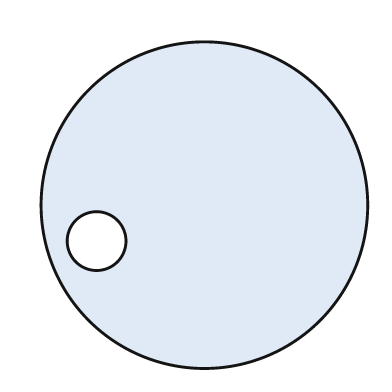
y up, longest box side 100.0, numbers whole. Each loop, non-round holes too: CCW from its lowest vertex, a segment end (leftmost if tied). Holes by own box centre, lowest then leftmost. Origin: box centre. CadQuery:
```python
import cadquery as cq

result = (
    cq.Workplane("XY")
    .moveTo(0.0, 0.0)
    .circle(50.0)
    .moveTo(-33.0, -11.0)
    .circle(9.0)
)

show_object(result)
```